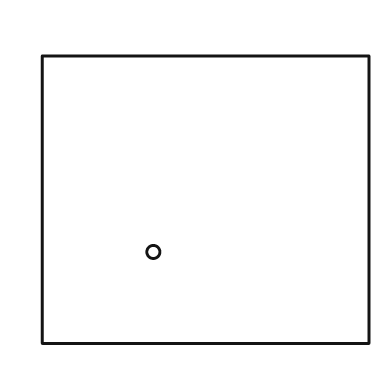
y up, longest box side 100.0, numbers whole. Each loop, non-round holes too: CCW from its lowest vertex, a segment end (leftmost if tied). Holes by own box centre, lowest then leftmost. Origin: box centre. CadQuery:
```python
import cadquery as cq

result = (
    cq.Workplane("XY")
    .moveTo(-50.0, -44.0)
    .lineTo(50.0, -44.0)
    .lineTo(50.0, 44.0)
    .lineTo(-50.0, 44.0)
    .close()
    .moveTo(-16.0, -16.0)
    .circle(2.0)
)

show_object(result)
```